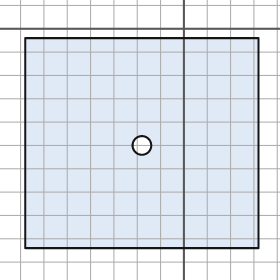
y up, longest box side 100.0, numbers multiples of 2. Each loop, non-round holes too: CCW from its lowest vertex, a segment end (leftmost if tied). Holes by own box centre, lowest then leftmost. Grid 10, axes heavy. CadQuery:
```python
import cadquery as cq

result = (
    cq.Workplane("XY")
    .moveTo(-68.0, -94.0)
    .lineTo(32.0, -94.0)
    .lineTo(32.0, -4.0)
    .lineTo(-68.0, -4.0)
    .close()
    .moveTo(-18.0, -50.0)
    .circle(4.0)
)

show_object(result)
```